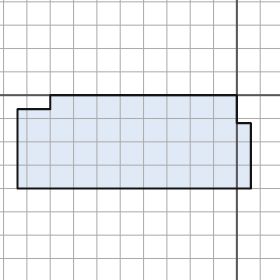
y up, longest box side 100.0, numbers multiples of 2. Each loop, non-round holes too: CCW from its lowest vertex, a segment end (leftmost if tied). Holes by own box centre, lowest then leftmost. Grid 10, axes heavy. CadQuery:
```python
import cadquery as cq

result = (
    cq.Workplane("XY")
    .moveTo(-94.0, -40.0)
    .lineTo(6.0, -40.0)
    .lineTo(6.0, -12.0)
    .lineTo(0.0, -12.0)
    .lineTo(0.0, 0.0)
    .lineTo(-80.0, 0.0)
    .lineTo(-80.0, -6.0)
    .lineTo(-94.0, -6.0)
    .close()
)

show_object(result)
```